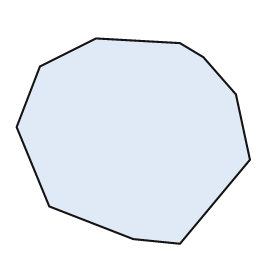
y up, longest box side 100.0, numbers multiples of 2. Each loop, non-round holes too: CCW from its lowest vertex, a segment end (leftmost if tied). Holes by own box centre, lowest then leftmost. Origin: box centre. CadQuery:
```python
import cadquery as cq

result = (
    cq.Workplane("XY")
    .moveTo(20.0, -44.0)
    .lineTo(50.0, -8.0)
    .lineTo(44.0, 20.0)
    .lineTo(30.0, 36.0)
    .lineTo(20.0, 42.0)
    .lineTo(-16.0, 44.0)
    .lineTo(-40.0, 32.0)
    .lineTo(-50.0, 6.0)
    .lineTo(-36.0, -28.0)
    .lineTo(0.0, -42.0)
    .close()
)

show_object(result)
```